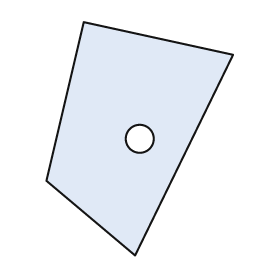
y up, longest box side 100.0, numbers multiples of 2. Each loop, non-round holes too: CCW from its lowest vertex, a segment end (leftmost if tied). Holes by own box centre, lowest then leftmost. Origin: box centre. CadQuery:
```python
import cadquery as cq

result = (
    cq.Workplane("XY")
    .moveTo(-2.0, -50.0)
    .lineTo(40.0, 36.0)
    .lineTo(-24.0, 50.0)
    .lineTo(-40.0, -18.0)
    .close()
    .moveTo(0.0, 0.0)
    .circle(6.0)
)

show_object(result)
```